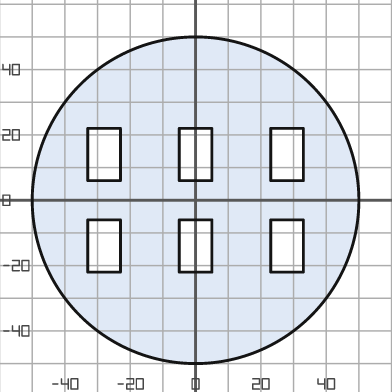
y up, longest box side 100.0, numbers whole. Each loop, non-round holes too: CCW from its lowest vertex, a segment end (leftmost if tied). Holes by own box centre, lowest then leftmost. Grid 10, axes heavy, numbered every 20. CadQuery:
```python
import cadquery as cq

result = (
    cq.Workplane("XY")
    .moveTo(0.0, 0.0)
    .circle(50.0)
    .moveTo(-33.0, -22.0)
    .lineTo(-23.0, -22.0)
    .lineTo(-23.0, -6.0)
    .lineTo(-33.0, -6.0)
    .close()
    .moveTo(-5.0, -22.0)
    .lineTo(5.0, -22.0)
    .lineTo(5.0, -6.0)
    .lineTo(-5.0, -6.0)
    .close()
    .moveTo(23.0, -22.0)
    .lineTo(33.0, -22.0)
    .lineTo(33.0, -6.0)
    .lineTo(23.0, -6.0)
    .close()
    .moveTo(-33.0, 6.0)
    .lineTo(-23.0, 6.0)
    .lineTo(-23.0, 22.0)
    .lineTo(-33.0, 22.0)
    .close()
    .moveTo(-5.0, 6.0)
    .lineTo(5.0, 6.0)
    .lineTo(5.0, 22.0)
    .lineTo(-5.0, 22.0)
    .close()
    .moveTo(23.0, 6.0)
    .lineTo(33.0, 6.0)
    .lineTo(33.0, 22.0)
    .lineTo(23.0, 22.0)
    .close()
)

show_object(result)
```